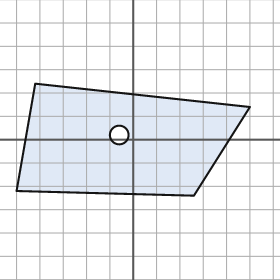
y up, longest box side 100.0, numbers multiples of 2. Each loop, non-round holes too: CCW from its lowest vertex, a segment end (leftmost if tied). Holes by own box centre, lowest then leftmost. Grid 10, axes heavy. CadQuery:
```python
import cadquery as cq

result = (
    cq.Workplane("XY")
    .moveTo(26.0, -24.0)
    .lineTo(50.0, 14.0)
    .lineTo(-42.0, 24.0)
    .lineTo(-50.0, -22.0)
    .close()
    .moveTo(-6.0, 2.0)
    .circle(4.0)
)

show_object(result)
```